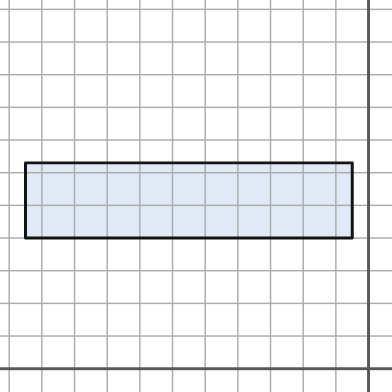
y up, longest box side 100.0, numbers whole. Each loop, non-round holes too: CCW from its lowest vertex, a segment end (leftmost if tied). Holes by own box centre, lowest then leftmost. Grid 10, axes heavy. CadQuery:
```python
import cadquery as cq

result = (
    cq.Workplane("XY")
    .moveTo(-105.0, 40.0)
    .lineTo(-5.0, 40.0)
    .lineTo(-5.0, 63.0)
    .lineTo(-105.0, 63.0)
    .close()
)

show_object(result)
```